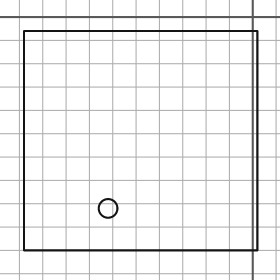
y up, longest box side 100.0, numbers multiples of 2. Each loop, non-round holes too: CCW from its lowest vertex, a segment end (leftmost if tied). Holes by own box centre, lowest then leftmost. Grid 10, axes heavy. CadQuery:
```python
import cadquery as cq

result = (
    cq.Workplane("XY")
    .moveTo(-98.0, -100.0)
    .lineTo(2.0, -100.0)
    .lineTo(2.0, -6.0)
    .lineTo(-98.0, -6.0)
    .close()
    .moveTo(-62.0, -82.0)
    .circle(4.0)
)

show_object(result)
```